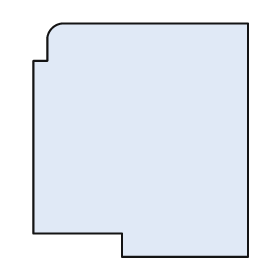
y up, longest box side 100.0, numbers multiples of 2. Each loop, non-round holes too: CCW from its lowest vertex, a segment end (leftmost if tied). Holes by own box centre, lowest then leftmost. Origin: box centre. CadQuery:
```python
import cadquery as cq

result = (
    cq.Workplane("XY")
    .moveTo(-8.0, -50.0)
    .lineTo(46.0, -50.0)
    .lineTo(46.0, 50.0)
    .lineTo(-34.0, 50.0)
    .threePointArc((-38.0, 48.0), (-40.0, 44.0))
    .lineTo(-40.0, 34.0)
    .lineTo(-46.0, 34.0)
    .lineTo(-46.0, -40.0)
    .lineTo(-8.0, -40.0)
    .close()
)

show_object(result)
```